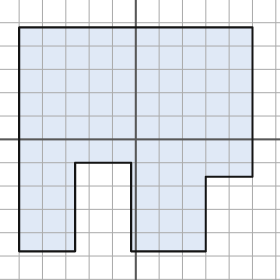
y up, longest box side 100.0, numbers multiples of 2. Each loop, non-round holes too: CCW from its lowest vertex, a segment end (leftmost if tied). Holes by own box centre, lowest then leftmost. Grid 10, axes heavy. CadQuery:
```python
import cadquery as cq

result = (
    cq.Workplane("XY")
    .moveTo(-50.0, -48.0)
    .lineTo(-26.0, -48.0)
    .lineTo(-26.0, -10.0)
    .lineTo(-2.0, -10.0)
    .lineTo(-2.0, -48.0)
    .lineTo(30.0, -48.0)
    .lineTo(30.0, -16.0)
    .lineTo(50.0, -16.0)
    .lineTo(50.0, 48.0)
    .lineTo(-50.0, 48.0)
    .close()
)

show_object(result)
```